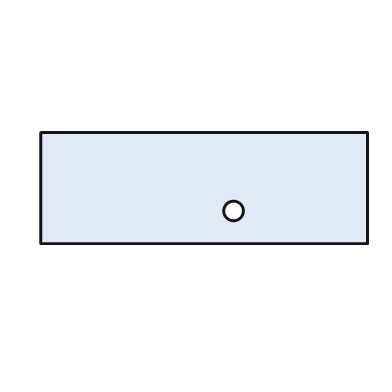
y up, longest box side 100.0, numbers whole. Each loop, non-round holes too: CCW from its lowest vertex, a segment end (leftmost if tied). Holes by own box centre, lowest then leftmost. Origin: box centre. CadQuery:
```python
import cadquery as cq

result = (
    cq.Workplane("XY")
    .moveTo(-50.0, -17.0)
    .lineTo(50.0, -17.0)
    .lineTo(50.0, 17.0)
    .lineTo(-50.0, 17.0)
    .close()
    .moveTo(9.0, -7.0)
    .circle(3.0)
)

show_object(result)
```